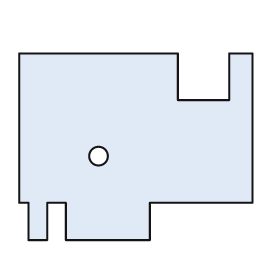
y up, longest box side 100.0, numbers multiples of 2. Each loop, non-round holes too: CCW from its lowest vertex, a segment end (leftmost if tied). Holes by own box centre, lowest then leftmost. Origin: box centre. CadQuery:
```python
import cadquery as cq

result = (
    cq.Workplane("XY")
    .moveTo(-46.0, -40.0)
    .lineTo(-38.0, -40.0)
    .lineTo(-38.0, -24.0)
    .lineTo(-30.0, -24.0)
    .lineTo(-30.0, -40.0)
    .lineTo(6.0, -40.0)
    .lineTo(6.0, -24.0)
    .lineTo(50.0, -24.0)
    .lineTo(50.0, 40.0)
    .lineTo(40.0, 40.0)
    .lineTo(40.0, 20.0)
    .lineTo(18.0, 20.0)
    .lineTo(18.0, 40.0)
    .lineTo(-50.0, 40.0)
    .lineTo(-50.0, -24.0)
    .lineTo(-46.0, -24.0)
    .close()
    .moveTo(-16.0, -4.0)
    .circle(4.0)
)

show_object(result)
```